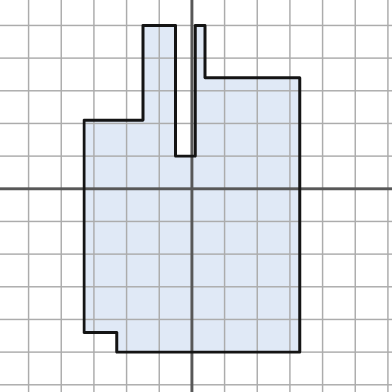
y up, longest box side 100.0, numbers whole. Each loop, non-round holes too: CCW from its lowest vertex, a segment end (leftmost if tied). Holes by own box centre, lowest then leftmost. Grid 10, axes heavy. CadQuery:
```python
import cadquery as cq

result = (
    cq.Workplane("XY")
    .moveTo(-23.0, -50.0)
    .lineTo(33.0, -50.0)
    .lineTo(33.0, 34.0)
    .lineTo(4.0, 34.0)
    .lineTo(4.0, 50.0)
    .lineTo(1.0, 50.0)
    .lineTo(1.0, 10.0)
    .lineTo(-5.0, 10.0)
    .lineTo(-5.0, 50.0)
    .lineTo(-15.0, 50.0)
    .lineTo(-15.0, 21.0)
    .lineTo(-33.0, 21.0)
    .lineTo(-33.0, -44.0)
    .lineTo(-23.0, -44.0)
    .close()
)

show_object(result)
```